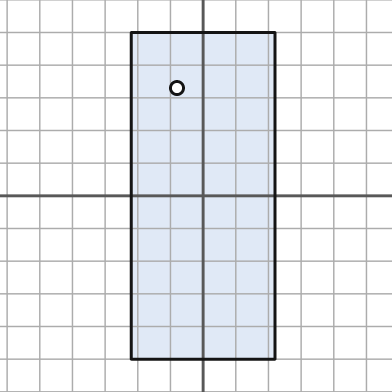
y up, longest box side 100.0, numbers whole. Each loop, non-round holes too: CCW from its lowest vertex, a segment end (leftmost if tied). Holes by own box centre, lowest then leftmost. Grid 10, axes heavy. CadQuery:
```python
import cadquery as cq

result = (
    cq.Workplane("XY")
    .moveTo(-22.0, -50.0)
    .lineTo(22.0, -50.0)
    .lineTo(22.0, 50.0)
    .lineTo(-22.0, 50.0)
    .close()
    .moveTo(-8.0, 33.0)
    .circle(2.0)
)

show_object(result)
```